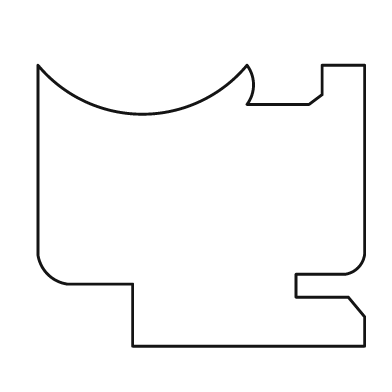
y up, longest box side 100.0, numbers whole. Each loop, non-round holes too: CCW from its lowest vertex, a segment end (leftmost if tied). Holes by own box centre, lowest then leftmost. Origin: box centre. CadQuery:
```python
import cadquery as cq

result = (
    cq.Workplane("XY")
    .moveTo(-21.0, -43.0)
    .lineTo(50.0, -43.0)
    .lineTo(50.0, -34.0)
    .lineTo(45.0, -28.0)
    .lineTo(29.0, -28.0)
    .lineTo(29.0, -21.0)
    .lineTo(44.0, -21.0)
    .threePointArc((48.0, -19.0), (50.0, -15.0))
    .lineTo(50.0, 43.0)
    .lineTo(37.0, 43.0)
    .lineTo(37.0, 34.0)
    .lineTo(33.0, 31.0)
    .lineTo(14.0, 31.0)
    .threePointArc((16.0, 37.0), (14.0, 43.0))
    .threePointArc((-18.0, 28.0), (-50.0, 43.0))
    .lineTo(-50.0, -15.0)
    .threePointArc((-47.0, -21.0), (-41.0, -24.0))
    .lineTo(-21.0, -24.0)
    .close()
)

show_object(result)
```